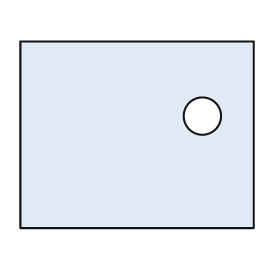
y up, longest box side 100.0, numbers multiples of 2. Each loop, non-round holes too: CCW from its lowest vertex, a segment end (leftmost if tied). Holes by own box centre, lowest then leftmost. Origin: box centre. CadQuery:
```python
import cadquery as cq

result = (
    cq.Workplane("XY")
    .moveTo(-50.0, -40.0)
    .lineTo(50.0, -40.0)
    .lineTo(50.0, 40.0)
    .lineTo(-50.0, 40.0)
    .close()
    .moveTo(28.0, 8.0)
    .circle(8.0)
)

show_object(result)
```